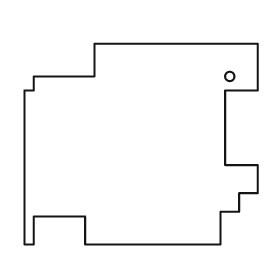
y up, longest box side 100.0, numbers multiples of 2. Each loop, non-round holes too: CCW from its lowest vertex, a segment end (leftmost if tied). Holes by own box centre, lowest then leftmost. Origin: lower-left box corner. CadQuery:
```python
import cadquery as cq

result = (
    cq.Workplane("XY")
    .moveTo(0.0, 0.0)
    .lineTo(4.0, 0.0)
    .lineTo(4.0, 12.0)
    .lineTo(26.0, 12.0)
    .lineTo(26.0, 0.0)
    .lineTo(84.0, 0.0)
    .lineTo(84.0, 14.0)
    .lineTo(92.0, 14.0)
    .lineTo(92.0, 22.0)
    .lineTo(100.0, 22.0)
    .lineTo(100.0, 34.0)
    .lineTo(86.0, 34.0)
    .lineTo(86.0, 66.0)
    .lineTo(100.0, 66.0)
    .lineTo(100.0, 86.0)
    .lineTo(30.0, 86.0)
    .lineTo(30.0, 72.0)
    .lineTo(4.0, 72.0)
    .lineTo(4.0, 66.0)
    .lineTo(0.0, 66.0)
    .close()
    .moveTo(88.0, 72.0)
    .circle(2.0)
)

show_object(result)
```